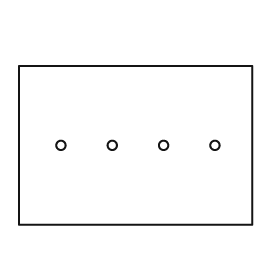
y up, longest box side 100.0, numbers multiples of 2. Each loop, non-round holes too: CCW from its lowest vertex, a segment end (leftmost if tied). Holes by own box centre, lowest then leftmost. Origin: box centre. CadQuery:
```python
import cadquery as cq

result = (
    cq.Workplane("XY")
    .moveTo(-50.0, -34.0)
    .lineTo(50.0, -34.0)
    .lineTo(50.0, 34.0)
    .lineTo(-50.0, 34.0)
    .close()
    .moveTo(-32.0, 0.0)
    .circle(2.0)
    .moveTo(-10.0, 0.0)
    .circle(2.0)
    .moveTo(12.0, 0.0)
    .circle(2.0)
    .moveTo(34.0, 0.0)
    .circle(2.0)
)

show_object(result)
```